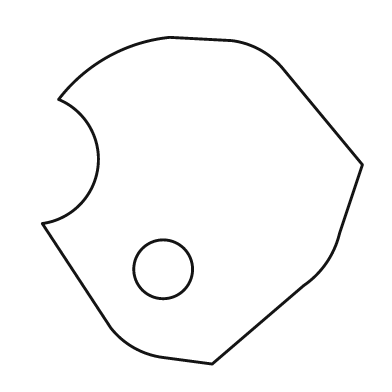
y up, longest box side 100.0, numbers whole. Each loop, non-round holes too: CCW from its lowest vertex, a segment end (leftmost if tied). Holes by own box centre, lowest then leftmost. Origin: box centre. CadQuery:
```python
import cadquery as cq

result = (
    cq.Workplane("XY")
    .moveTo(3.0, -50.0)
    .lineTo(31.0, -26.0)
    .threePointArc((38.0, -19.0), (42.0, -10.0))
    .lineTo(49.0, 11.0)
    .lineTo(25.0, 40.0)
    .threePointArc((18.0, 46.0), (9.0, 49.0))
    .lineTo(-10.0, 50.0)
    .threePointArc((-29.0, 44.0), (-44.0, 31.0))
    .threePointArc((-32.0, 10.0), (-49.0, -7.0))
    .lineTo(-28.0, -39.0)
    .threePointArc((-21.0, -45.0), (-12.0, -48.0))
    .close()
    .moveTo(-12.0, -21.0)
    .circle(9.0)
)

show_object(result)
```